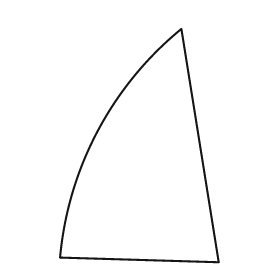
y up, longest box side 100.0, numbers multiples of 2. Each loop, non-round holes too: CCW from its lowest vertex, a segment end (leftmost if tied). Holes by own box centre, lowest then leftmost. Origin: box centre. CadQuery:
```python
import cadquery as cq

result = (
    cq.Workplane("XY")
    .moveTo(34.0, -50.0)
    .lineTo(18.0, 50.0)
    .threePointArc((-18.0, 6.0), (-34.0, -48.0))
    .close()
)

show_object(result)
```